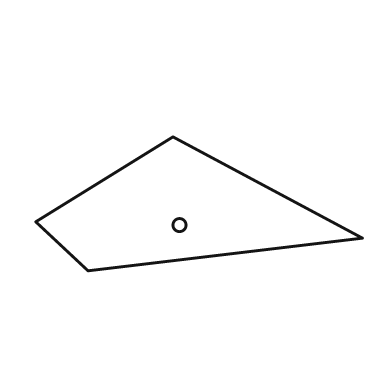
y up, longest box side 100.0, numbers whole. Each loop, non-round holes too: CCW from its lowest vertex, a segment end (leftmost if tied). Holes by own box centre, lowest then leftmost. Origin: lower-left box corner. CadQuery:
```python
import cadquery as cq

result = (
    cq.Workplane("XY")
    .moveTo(16.0, 0.0)
    .lineTo(100.0, 10.0)
    .lineTo(42.0, 41.0)
    .lineTo(0.0, 15.0)
    .close()
    .moveTo(44.0, 14.0)
    .circle(2.0)
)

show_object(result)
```